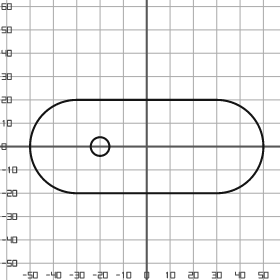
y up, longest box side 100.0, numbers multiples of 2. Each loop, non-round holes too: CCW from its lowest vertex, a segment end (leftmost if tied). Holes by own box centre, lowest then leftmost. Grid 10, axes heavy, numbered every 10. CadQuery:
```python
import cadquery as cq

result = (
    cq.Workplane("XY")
    .moveTo(-30.0, -20.0)
    .lineTo(30.0, -20.0)
    .threePointArc((50.0, 0.0), (30.0, 20.0))
    .lineTo(-30.0, 20.0)
    .threePointArc((-50.0, 0.0), (-30.0, -20.0))
    .close()
    .moveTo(-20.0, 0.0)
    .circle(4.0)
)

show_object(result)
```